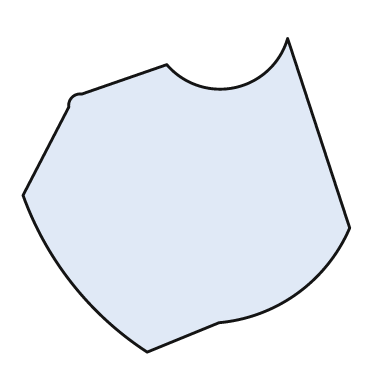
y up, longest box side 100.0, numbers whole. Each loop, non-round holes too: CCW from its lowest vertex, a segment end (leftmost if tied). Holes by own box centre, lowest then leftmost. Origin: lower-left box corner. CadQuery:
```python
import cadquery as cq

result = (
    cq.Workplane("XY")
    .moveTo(38.0, 0.0)
    .lineTo(60.0, 9.0)
    .threePointArc((84.0, 18.0), (100.0, 38.0))
    .lineTo(81.0, 96.0)
    .threePointArc((65.0, 81.0), (44.0, 88.0))
    .lineTo(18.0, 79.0)
    .threePointArc((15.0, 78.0), (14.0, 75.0))
    .lineTo(0.0, 48.0)
    .threePointArc((15.0, 21.0), (38.0, 0.0))
    .close()
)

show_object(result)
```